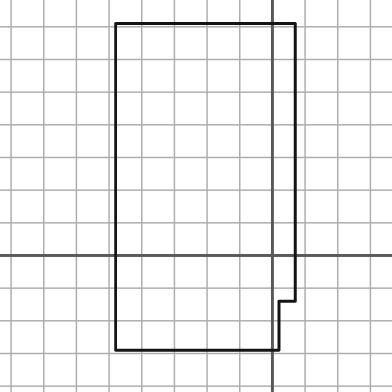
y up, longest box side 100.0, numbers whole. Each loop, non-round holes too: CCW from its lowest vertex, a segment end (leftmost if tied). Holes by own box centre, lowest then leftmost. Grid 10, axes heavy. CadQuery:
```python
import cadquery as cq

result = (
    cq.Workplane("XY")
    .moveTo(-48.0, -29.0)
    .lineTo(2.0, -29.0)
    .lineTo(2.0, -14.0)
    .lineTo(7.0, -14.0)
    .lineTo(7.0, 71.0)
    .lineTo(-48.0, 71.0)
    .close()
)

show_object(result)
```